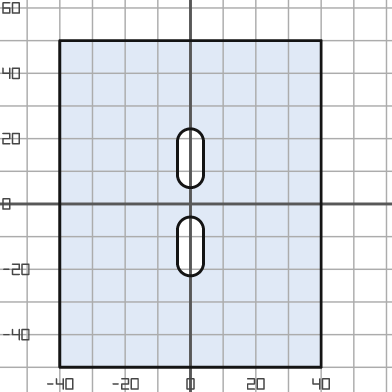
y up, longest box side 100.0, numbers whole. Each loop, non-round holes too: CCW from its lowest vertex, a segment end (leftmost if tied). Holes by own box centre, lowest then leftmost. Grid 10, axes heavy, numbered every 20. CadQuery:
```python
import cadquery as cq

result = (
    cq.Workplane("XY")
    .moveTo(-40.0, -50.0)
    .lineTo(40.0, -50.0)
    .lineTo(40.0, 50.0)
    .lineTo(-40.0, 50.0)
    .close()
    .moveTo(-4.0, -18.0)
    .threePointArc((0.0, -22.0), (4.0, -18.0))
    .lineTo(4.0, -8.0)
    .threePointArc((0.0, -4.0), (-4.0, -8.0))
    .close()
    .moveTo(-4.0, 9.0)
    .threePointArc((0.0, 5.0), (4.0, 9.0))
    .lineTo(4.0, 19.0)
    .threePointArc((0.0, 23.0), (-4.0, 19.0))
    .close()
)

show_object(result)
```